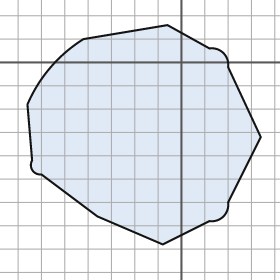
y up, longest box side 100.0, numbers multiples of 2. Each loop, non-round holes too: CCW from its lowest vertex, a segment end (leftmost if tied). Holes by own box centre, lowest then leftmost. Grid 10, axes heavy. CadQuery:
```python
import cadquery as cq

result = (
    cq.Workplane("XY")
    .moveTo(-8.0, -78.0)
    .lineTo(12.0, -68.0)
    .threePointArc((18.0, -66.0), (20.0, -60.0))
    .lineTo(34.0, -32.0)
    .lineTo(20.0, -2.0)
    .threePointArc((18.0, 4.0), (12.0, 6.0))
    .lineTo(-6.0, 16.0)
    .lineTo(-42.0, 10.0)
    .threePointArc((-56.0, -2.0), (-66.0, -18.0))
    .lineTo(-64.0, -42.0)
    .threePointArc((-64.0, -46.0), (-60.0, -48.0))
    .lineTo(-36.0, -66.0)
    .close()
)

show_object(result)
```